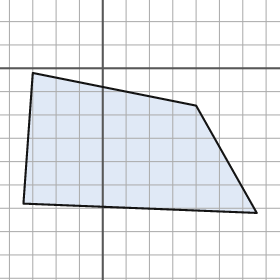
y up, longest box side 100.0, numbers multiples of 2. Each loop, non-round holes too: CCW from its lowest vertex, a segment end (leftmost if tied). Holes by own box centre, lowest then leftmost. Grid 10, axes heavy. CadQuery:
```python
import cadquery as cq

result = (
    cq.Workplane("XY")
    .moveTo(66.0, -62.0)
    .lineTo(40.0, -16.0)
    .lineTo(-30.0, -2.0)
    .lineTo(-34.0, -58.0)
    .close()
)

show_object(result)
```